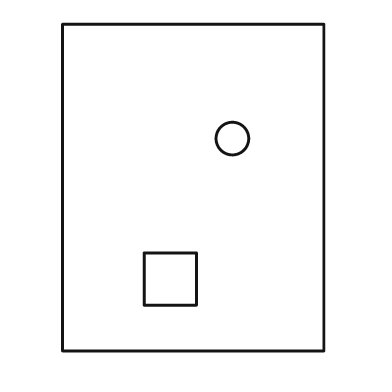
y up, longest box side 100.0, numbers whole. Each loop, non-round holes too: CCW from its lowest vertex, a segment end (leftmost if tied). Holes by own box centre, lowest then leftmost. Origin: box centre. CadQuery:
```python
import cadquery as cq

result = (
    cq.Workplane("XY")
    .moveTo(-40.0, -50.0)
    .lineTo(40.0, -50.0)
    .lineTo(40.0, 50.0)
    .lineTo(-40.0, 50.0)
    .close()
    .moveTo(-15.0, -36.0)
    .lineTo(1.0, -36.0)
    .lineTo(1.0, -20.0)
    .lineTo(-15.0, -20.0)
    .close()
    .moveTo(12.0, 15.0)
    .circle(5.0)
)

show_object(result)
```